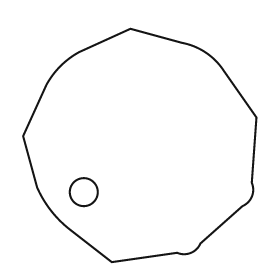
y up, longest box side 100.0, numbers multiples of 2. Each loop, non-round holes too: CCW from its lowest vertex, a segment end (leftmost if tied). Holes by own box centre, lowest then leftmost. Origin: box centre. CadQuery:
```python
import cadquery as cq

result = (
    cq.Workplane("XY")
    .moveTo(-12.0, -50.0)
    .lineTo(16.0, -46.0)
    .threePointArc((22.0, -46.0), (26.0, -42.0))
    .lineTo(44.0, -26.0)
    .threePointArc((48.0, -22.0), (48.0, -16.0))
    .lineTo(50.0, 12.0)
    .lineTo(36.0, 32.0)
    .threePointArc((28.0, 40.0), (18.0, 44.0))
    .lineTo(-4.0, 50.0)
    .lineTo(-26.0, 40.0)
    .threePointArc((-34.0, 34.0), (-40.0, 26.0))
    .lineTo(-50.0, 4.0)
    .lineTo(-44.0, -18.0)
    .threePointArc((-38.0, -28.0), (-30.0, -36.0))
    .close()
    .moveTo(-24.0, -20.0)
    .circle(6.0)
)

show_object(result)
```